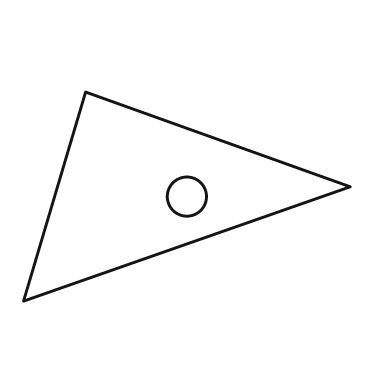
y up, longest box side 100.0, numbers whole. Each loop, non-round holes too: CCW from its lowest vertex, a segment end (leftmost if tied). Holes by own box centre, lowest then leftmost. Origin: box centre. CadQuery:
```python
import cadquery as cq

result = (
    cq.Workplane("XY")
    .moveTo(-50.0, -32.0)
    .lineTo(50.0, 3.0)
    .lineTo(-31.0, 32.0)
    .close()
    .moveTo(0.0, 0.0)
    .circle(6.0)
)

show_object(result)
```